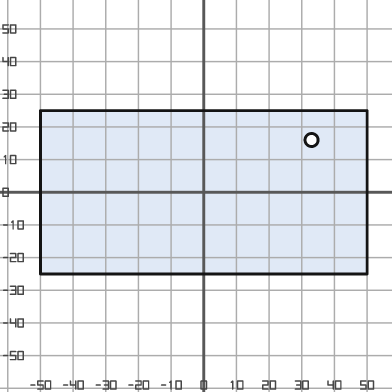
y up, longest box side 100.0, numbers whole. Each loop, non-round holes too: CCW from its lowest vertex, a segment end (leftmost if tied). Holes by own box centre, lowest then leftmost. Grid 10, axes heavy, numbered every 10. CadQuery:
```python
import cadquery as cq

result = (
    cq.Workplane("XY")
    .moveTo(-50.0, -25.0)
    .lineTo(50.0, -25.0)
    .lineTo(50.0, 25.0)
    .lineTo(-50.0, 25.0)
    .close()
    .moveTo(33.0, 16.0)
    .circle(2.0)
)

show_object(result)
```